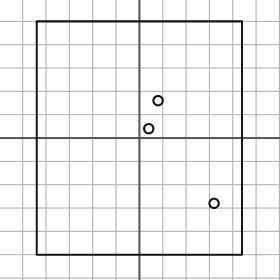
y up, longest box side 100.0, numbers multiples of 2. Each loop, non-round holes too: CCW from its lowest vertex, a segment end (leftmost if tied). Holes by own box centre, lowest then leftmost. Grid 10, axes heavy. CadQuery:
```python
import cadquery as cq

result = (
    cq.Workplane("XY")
    .moveTo(-44.0, -50.0)
    .lineTo(44.0, -50.0)
    .lineTo(44.0, 50.0)
    .lineTo(-44.0, 50.0)
    .close()
    .moveTo(32.0, -28.0)
    .circle(2.0)
    .moveTo(4.0, 4.0)
    .circle(2.0)
    .moveTo(8.0, 16.0)
    .circle(2.0)
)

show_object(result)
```